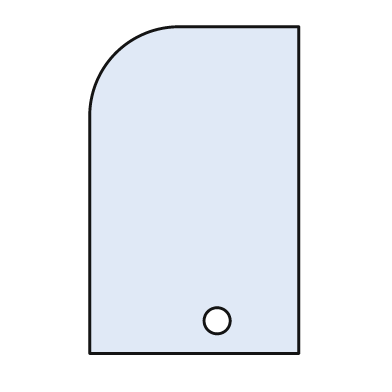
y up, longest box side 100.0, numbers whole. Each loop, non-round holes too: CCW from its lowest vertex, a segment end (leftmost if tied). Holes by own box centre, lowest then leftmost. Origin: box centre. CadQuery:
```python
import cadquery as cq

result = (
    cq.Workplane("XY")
    .moveTo(-32.0, -50.0)
    .lineTo(32.0, -50.0)
    .lineTo(32.0, 50.0)
    .lineTo(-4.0, 50.0)
    .threePointArc((-24.0, 42.0), (-32.0, 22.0))
    .close()
    .moveTo(7.0, -40.0)
    .circle(4.0)
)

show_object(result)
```